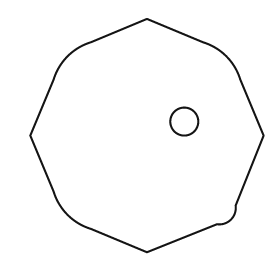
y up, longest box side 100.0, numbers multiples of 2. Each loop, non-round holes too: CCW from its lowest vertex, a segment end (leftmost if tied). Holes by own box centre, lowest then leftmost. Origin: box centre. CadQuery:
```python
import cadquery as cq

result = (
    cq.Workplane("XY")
    .moveTo(0.0, -50.0)
    .lineTo(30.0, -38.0)
    .threePointArc((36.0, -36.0), (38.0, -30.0))
    .lineTo(50.0, 0.0)
    .lineTo(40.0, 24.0)
    .threePointArc((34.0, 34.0), (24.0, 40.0))
    .lineTo(0.0, 50.0)
    .lineTo(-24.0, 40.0)
    .threePointArc((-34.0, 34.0), (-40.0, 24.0))
    .lineTo(-50.0, 0.0)
    .lineTo(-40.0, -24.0)
    .threePointArc((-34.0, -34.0), (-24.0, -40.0))
    .close()
    .moveTo(16.0, 6.0)
    .circle(6.0)
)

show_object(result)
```